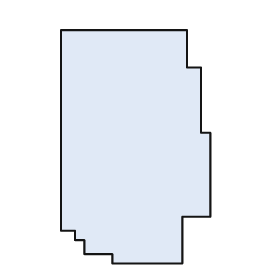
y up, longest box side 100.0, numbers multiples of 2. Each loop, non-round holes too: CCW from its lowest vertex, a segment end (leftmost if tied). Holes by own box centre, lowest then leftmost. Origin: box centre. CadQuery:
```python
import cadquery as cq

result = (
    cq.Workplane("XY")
    .moveTo(-10.0, -50.0)
    .lineTo(20.0, -50.0)
    .lineTo(20.0, -30.0)
    .lineTo(32.0, -30.0)
    .lineTo(32.0, 6.0)
    .lineTo(28.0, 6.0)
    .lineTo(28.0, 34.0)
    .lineTo(22.0, 34.0)
    .lineTo(22.0, 50.0)
    .lineTo(-32.0, 50.0)
    .lineTo(-32.0, -36.0)
    .lineTo(-26.0, -36.0)
    .lineTo(-26.0, -40.0)
    .lineTo(-22.0, -40.0)
    .lineTo(-22.0, -46.0)
    .lineTo(-10.0, -46.0)
    .close()
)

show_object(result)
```